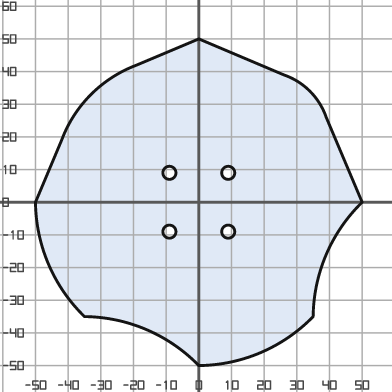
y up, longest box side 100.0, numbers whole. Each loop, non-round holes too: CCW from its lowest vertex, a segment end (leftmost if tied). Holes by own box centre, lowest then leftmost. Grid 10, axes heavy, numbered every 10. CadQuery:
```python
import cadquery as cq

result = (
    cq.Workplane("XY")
    .moveTo(0.0, -50.0)
    .threePointArc((19.0, -46.0), (35.0, -35.0))
    .threePointArc((39.0, -16.0), (50.0, 0.0))
    .lineTo(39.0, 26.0)
    .threePointArc((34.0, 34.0), (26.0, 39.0))
    .lineTo(0.0, 50.0)
    .lineTo(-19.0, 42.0)
    .threePointArc((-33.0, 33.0), (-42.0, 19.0))
    .lineTo(-50.0, 0.0)
    .threePointArc((-46.0, -19.0), (-35.0, -35.0))
    .threePointArc((-16.0, -39.0), (0.0, -50.0))
    .close()
    .moveTo(-9.0, -9.0)
    .circle(2.0)
    .moveTo(9.0, -9.0)
    .circle(2.0)
    .moveTo(-9.0, 9.0)
    .circle(2.0)
    .moveTo(9.0, 9.0)
    .circle(2.0)
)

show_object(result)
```